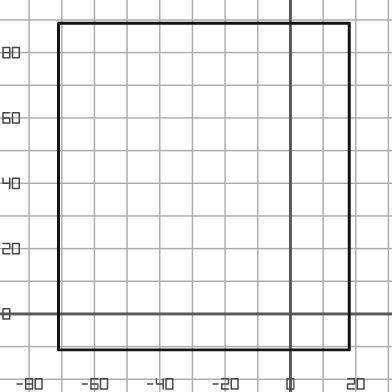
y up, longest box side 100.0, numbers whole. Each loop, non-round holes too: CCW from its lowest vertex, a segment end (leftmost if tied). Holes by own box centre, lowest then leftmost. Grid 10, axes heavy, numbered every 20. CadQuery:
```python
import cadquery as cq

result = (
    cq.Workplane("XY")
    .moveTo(-71.0, -11.0)
    .lineTo(18.0, -11.0)
    .lineTo(18.0, 89.0)
    .lineTo(-71.0, 89.0)
    .close()
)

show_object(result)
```